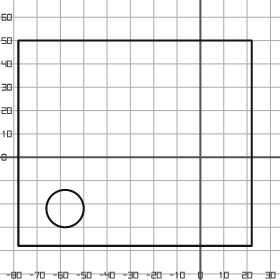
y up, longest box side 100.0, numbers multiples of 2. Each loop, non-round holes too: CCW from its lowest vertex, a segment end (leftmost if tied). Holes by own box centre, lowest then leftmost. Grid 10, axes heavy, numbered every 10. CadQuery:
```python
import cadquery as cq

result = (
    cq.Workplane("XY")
    .moveTo(-78.0, -38.0)
    .lineTo(22.0, -38.0)
    .lineTo(22.0, 50.0)
    .lineTo(-78.0, 50.0)
    .close()
    .moveTo(-58.0, -22.0)
    .circle(8.0)
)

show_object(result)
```